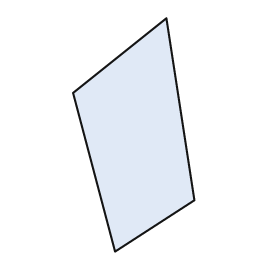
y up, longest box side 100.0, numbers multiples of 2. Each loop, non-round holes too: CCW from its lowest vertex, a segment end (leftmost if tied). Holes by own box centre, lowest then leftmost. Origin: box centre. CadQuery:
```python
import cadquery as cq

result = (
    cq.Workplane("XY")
    .moveTo(-8.0, -50.0)
    .lineTo(26.0, -28.0)
    .lineTo(14.0, 50.0)
    .lineTo(-26.0, 18.0)
    .close()
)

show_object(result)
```